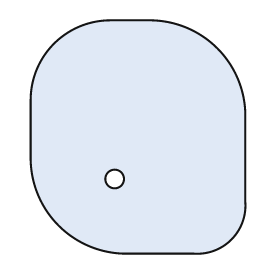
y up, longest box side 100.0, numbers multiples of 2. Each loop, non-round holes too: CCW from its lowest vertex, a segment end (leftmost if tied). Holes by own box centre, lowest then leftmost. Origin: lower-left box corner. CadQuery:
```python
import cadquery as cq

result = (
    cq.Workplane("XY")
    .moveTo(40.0, 0.0)
    .lineTo(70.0, 0.0)
    .threePointArc((86.0, 6.0), (92.0, 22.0))
    .lineTo(92.0, 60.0)
    .threePointArc((80.0, 88.0), (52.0, 100.0))
    .lineTo(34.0, 100.0)
    .threePointArc((10.0, 90.0), (0.0, 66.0))
    .lineTo(0.0, 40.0)
    .threePointArc((12.0, 12.0), (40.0, 0.0))
    .close()
    .moveTo(36.0, 32.0)
    .circle(4.0)
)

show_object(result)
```